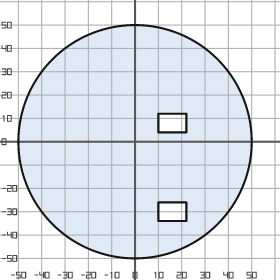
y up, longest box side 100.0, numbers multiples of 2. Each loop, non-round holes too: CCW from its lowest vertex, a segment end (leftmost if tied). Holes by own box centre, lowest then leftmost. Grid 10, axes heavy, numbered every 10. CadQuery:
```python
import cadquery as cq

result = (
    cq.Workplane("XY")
    .moveTo(0.0, 0.0)
    .circle(50.0)
    .moveTo(10.0, -34.0)
    .lineTo(22.0, -34.0)
    .lineTo(22.0, -26.0)
    .lineTo(10.0, -26.0)
    .close()
    .moveTo(10.0, 4.0)
    .lineTo(22.0, 4.0)
    .lineTo(22.0, 12.0)
    .lineTo(10.0, 12.0)
    .close()
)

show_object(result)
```